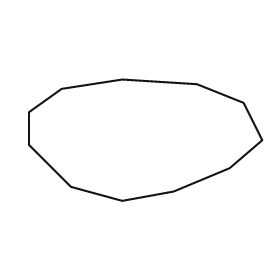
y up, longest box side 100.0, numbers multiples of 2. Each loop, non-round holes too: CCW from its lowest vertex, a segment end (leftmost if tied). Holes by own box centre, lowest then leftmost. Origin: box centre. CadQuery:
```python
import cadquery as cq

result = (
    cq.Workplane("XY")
    .moveTo(-10.0, -26.0)
    .lineTo(12.0, -22.0)
    .lineTo(36.0, -12.0)
    .lineTo(50.0, 0.0)
    .lineTo(42.0, 16.0)
    .lineTo(22.0, 24.0)
    .lineTo(-10.0, 26.0)
    .lineTo(-36.0, 22.0)
    .lineTo(-50.0, 12.0)
    .lineTo(-50.0, -2.0)
    .lineTo(-32.0, -20.0)
    .close()
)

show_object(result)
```